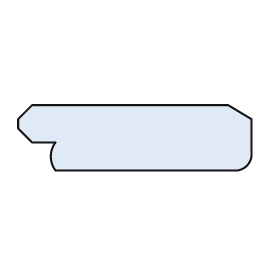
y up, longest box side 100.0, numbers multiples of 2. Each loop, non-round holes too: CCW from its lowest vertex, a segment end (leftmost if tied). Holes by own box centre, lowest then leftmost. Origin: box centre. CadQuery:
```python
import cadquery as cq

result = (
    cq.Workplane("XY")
    .moveTo(-34.0, -14.0)
    .lineTo(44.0, -14.0)
    .threePointArc((48.0, -12.0), (50.0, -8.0))
    .lineTo(50.0, 8.0)
    .lineTo(40.0, 14.0)
    .lineTo(-44.0, 14.0)
    .lineTo(-50.0, 8.0)
    .lineTo(-50.0, 4.0)
    .lineTo(-44.0, -2.0)
    .lineTo(-34.0, -2.0)
    .threePointArc((-36.0, -8.0), (-34.0, -14.0))
    .close()
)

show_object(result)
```